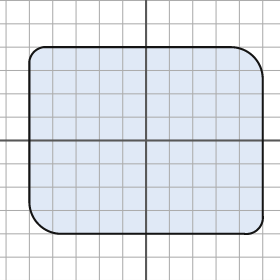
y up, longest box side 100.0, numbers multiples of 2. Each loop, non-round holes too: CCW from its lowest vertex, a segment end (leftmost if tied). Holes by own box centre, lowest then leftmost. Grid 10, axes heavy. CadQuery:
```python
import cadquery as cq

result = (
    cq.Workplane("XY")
    .moveTo(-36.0, -40.0)
    .lineTo(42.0, -40.0)
    .threePointArc((48.0, -38.0), (50.0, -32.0))
    .lineTo(50.0, 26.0)
    .threePointArc((46.0, 36.0), (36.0, 40.0))
    .lineTo(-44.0, 40.0)
    .threePointArc((-48.0, 38.0), (-50.0, 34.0))
    .lineTo(-50.0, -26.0)
    .threePointArc((-46.0, -36.0), (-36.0, -40.0))
    .close()
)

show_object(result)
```